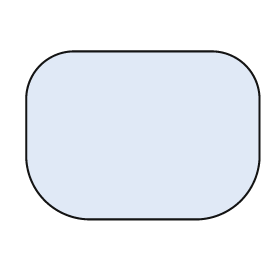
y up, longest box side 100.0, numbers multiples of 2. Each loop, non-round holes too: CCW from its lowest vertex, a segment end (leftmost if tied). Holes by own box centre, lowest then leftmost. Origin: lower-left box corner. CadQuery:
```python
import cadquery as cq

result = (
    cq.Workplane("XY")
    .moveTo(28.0, 0.0)
    .lineTo(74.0, 0.0)
    .threePointArc((92.0, 8.0), (100.0, 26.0))
    .lineTo(100.0, 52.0)
    .threePointArc((94.0, 66.0), (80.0, 72.0))
    .lineTo(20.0, 72.0)
    .threePointArc((6.0, 66.0), (0.0, 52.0))
    .lineTo(0.0, 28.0)
    .threePointArc((8.0, 8.0), (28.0, 0.0))
    .close()
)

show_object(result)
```